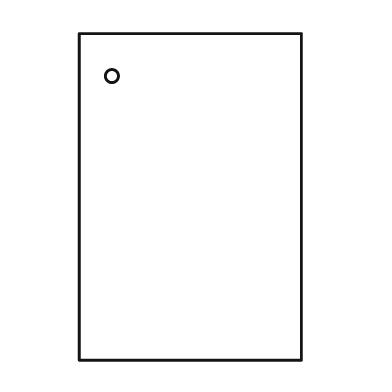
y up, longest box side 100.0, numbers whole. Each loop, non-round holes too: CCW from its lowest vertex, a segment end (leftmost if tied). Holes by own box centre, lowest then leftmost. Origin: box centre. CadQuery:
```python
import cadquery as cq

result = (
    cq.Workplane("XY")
    .moveTo(-34.0, -50.0)
    .lineTo(34.0, -50.0)
    .lineTo(34.0, 50.0)
    .lineTo(-34.0, 50.0)
    .close()
    .moveTo(-24.0, 37.0)
    .circle(2.0)
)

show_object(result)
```